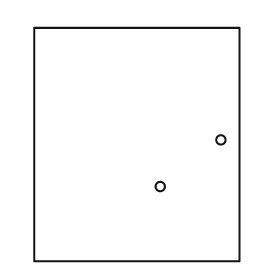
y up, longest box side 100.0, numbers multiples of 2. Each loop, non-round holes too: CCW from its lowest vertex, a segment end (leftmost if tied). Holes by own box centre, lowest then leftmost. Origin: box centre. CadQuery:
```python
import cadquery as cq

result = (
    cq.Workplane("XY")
    .moveTo(-44.0, -50.0)
    .lineTo(44.0, -50.0)
    .lineTo(44.0, 50.0)
    .lineTo(-44.0, 50.0)
    .close()
    .moveTo(10.0, -18.0)
    .circle(2.0)
    .moveTo(36.0, 2.0)
    .circle(2.0)
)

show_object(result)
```